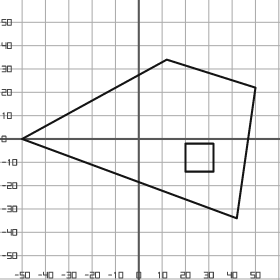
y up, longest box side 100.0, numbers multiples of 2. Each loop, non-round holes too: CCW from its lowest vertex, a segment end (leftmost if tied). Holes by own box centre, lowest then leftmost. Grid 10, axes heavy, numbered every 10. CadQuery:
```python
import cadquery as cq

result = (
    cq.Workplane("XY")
    .moveTo(42.0, -34.0)
    .lineTo(50.0, 22.0)
    .lineTo(12.0, 34.0)
    .lineTo(-50.0, 0.0)
    .close()
    .moveTo(20.0, -14.0)
    .lineTo(32.0, -14.0)
    .lineTo(32.0, -2.0)
    .lineTo(20.0, -2.0)
    .close()
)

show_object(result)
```